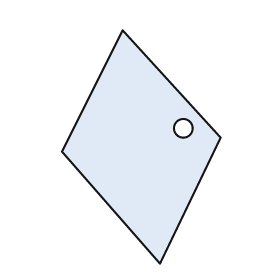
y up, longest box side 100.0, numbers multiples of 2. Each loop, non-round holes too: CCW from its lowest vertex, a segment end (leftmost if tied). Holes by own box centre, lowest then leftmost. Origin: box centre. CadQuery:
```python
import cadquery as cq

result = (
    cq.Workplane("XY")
    .moveTo(8.0, -50.0)
    .lineTo(34.0, 4.0)
    .lineTo(-8.0, 50.0)
    .lineTo(-34.0, -2.0)
    .close()
    .moveTo(18.0, 8.0)
    .circle(4.0)
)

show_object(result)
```